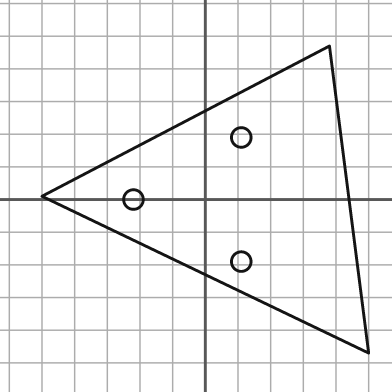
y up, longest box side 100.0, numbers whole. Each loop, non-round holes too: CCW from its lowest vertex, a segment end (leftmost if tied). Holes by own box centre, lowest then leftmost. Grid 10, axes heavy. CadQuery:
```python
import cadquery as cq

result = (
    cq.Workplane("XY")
    .moveTo(50.0, -47.0)
    .lineTo(38.0, 47.0)
    .lineTo(-50.0, 1.0)
    .close()
    .moveTo(11.0, -19.0)
    .circle(3.0)
    .moveTo(-22.0, 0.0)
    .circle(3.0)
    .moveTo(11.0, 19.0)
    .circle(3.0)
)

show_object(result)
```